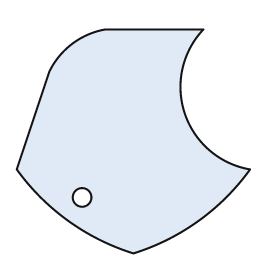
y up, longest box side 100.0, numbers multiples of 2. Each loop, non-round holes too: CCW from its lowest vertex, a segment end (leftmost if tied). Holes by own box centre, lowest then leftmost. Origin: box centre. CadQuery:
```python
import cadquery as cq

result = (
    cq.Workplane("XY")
    .moveTo(0.0, -48.0)
    .threePointArc((28.0, -34.0), (50.0, -12.0))
    .threePointArc((22.0, 12.0), (30.0, 48.0))
    .lineTo(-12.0, 48.0)
    .threePointArc((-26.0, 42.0), (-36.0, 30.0))
    .lineTo(-50.0, -12.0)
    .threePointArc((-28.0, -34.0), (0.0, -48.0))
    .close()
    .moveTo(-22.0, -24.0)
    .circle(4.0)
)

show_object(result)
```